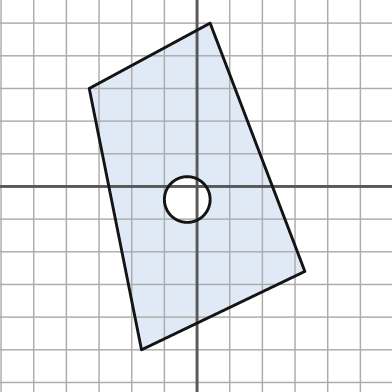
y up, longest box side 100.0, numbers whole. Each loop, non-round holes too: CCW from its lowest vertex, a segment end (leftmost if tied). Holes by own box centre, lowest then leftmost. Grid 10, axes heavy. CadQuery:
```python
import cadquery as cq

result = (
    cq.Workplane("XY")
    .moveTo(-17.0, -50.0)
    .lineTo(33.0, -26.0)
    .lineTo(4.0, 50.0)
    .lineTo(-33.0, 30.0)
    .close()
    .moveTo(-3.0, -4.0)
    .circle(7.0)
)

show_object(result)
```